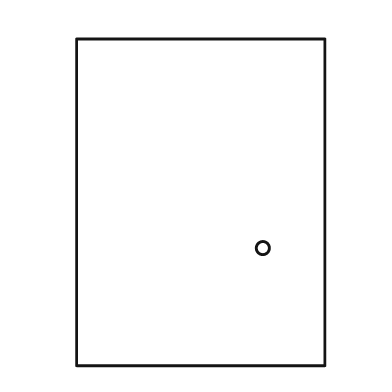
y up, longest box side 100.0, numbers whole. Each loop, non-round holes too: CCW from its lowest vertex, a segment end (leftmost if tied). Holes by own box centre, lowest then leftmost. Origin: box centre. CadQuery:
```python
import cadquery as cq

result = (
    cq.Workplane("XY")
    .moveTo(-38.0, -50.0)
    .lineTo(38.0, -50.0)
    .lineTo(38.0, 50.0)
    .lineTo(-38.0, 50.0)
    .close()
    .moveTo(19.0, -14.0)
    .circle(2.0)
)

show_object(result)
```